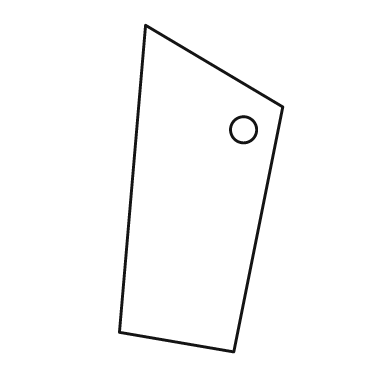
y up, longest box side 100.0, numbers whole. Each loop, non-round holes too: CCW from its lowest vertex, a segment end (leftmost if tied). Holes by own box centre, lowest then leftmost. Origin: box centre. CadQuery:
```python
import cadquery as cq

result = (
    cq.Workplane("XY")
    .moveTo(10.0, -50.0)
    .lineTo(25.0, 25.0)
    .lineTo(-17.0, 50.0)
    .lineTo(-25.0, -44.0)
    .close()
    .moveTo(13.0, 18.0)
    .circle(4.0)
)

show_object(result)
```